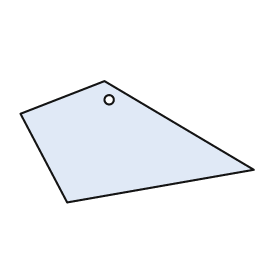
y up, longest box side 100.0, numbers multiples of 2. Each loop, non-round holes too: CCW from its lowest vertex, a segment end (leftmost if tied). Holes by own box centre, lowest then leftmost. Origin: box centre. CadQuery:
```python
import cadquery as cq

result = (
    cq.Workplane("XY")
    .moveTo(-30.0, -26.0)
    .lineTo(50.0, -12.0)
    .lineTo(-14.0, 26.0)
    .lineTo(-50.0, 12.0)
    .close()
    .moveTo(-12.0, 18.0)
    .circle(2.0)
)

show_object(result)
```